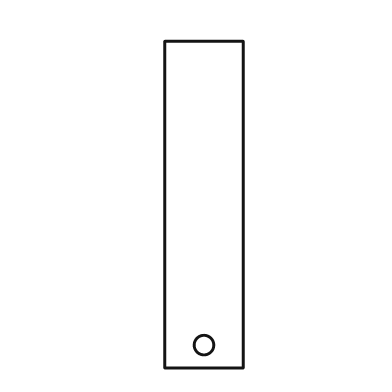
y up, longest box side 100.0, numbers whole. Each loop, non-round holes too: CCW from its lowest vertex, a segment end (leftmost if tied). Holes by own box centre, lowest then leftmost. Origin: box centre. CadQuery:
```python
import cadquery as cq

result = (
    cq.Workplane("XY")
    .moveTo(-12.0, -50.0)
    .lineTo(12.0, -50.0)
    .lineTo(12.0, 50.0)
    .lineTo(-12.0, 50.0)
    .close()
    .moveTo(0.0, -43.0)
    .circle(3.0)
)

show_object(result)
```